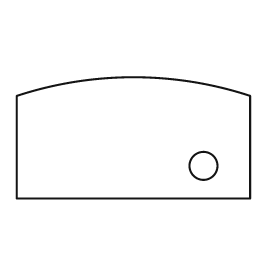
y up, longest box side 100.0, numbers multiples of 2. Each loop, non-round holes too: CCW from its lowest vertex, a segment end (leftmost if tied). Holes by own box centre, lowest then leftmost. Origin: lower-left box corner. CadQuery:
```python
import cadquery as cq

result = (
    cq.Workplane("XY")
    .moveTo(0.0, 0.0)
    .lineTo(100.0, 0.0)
    .lineTo(100.0, 44.0)
    .threePointArc((50.0, 52.0), (0.0, 44.0))
    .close()
    .moveTo(80.0, 14.0)
    .circle(6.0)
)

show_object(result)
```